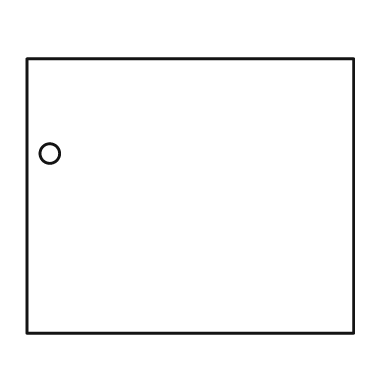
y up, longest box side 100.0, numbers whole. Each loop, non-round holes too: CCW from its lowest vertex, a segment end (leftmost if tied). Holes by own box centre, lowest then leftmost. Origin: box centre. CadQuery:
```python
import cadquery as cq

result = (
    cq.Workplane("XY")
    .moveTo(-50.0, -42.0)
    .lineTo(50.0, -42.0)
    .lineTo(50.0, 42.0)
    .lineTo(-50.0, 42.0)
    .close()
    .moveTo(-43.0, 13.0)
    .circle(3.0)
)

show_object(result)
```